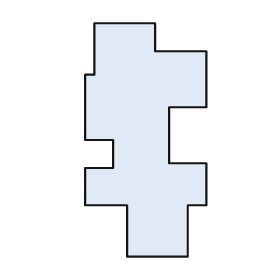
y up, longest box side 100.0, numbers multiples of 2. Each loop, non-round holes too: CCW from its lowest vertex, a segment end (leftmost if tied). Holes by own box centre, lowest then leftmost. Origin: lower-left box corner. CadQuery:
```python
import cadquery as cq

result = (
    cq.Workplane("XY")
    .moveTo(18.0, 0.0)
    .lineTo(44.0, 0.0)
    .lineTo(44.0, 22.0)
    .lineTo(52.0, 22.0)
    .lineTo(52.0, 40.0)
    .lineTo(36.0, 40.0)
    .lineTo(36.0, 64.0)
    .lineTo(52.0, 64.0)
    .lineTo(52.0, 88.0)
    .lineTo(30.0, 88.0)
    .lineTo(30.0, 100.0)
    .lineTo(4.0, 100.0)
    .lineTo(4.0, 78.0)
    .lineTo(0.0, 78.0)
    .lineTo(0.0, 50.0)
    .lineTo(12.0, 50.0)
    .lineTo(12.0, 38.0)
    .lineTo(0.0, 38.0)
    .lineTo(0.0, 22.0)
    .lineTo(18.0, 22.0)
    .close()
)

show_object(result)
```